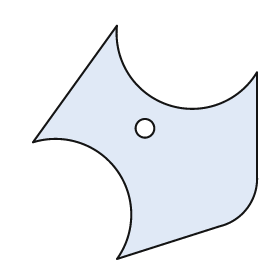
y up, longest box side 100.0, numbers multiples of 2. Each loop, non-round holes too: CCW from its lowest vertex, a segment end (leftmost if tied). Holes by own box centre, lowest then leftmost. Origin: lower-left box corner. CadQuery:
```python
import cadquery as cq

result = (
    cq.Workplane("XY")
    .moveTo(36.0, 0.0)
    .lineTo(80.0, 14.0)
    .threePointArc((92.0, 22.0), (96.0, 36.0))
    .lineTo(96.0, 80.0)
    .threePointArc((58.0, 66.0), (36.0, 100.0))
    .lineTo(0.0, 50.0)
    .threePointArc((36.0, 38.0), (36.0, 0.0))
    .close()
    .moveTo(48.0, 56.0)
    .circle(4.0)
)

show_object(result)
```